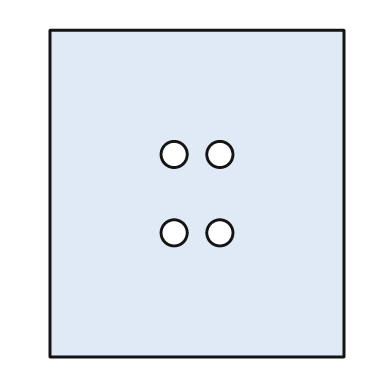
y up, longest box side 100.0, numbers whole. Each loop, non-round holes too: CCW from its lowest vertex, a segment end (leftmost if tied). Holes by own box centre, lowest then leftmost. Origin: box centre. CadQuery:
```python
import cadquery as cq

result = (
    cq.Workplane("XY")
    .moveTo(-45.0, -50.0)
    .lineTo(45.0, -50.0)
    .lineTo(45.0, 50.0)
    .lineTo(-45.0, 50.0)
    .close()
    .moveTo(-7.0, -12.0)
    .circle(4.0)
    .moveTo(7.0, -12.0)
    .circle(4.0)
    .moveTo(-7.0, 12.0)
    .circle(4.0)
    .moveTo(7.0, 12.0)
    .circle(4.0)
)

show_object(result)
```